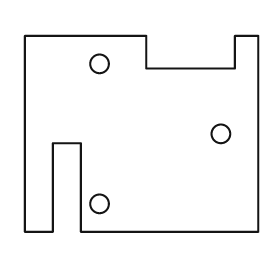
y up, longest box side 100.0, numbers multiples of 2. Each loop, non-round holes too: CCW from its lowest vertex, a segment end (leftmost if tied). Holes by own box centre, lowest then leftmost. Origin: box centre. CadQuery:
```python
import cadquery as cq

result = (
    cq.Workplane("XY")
    .moveTo(-50.0, -42.0)
    .lineTo(-38.0, -42.0)
    .lineTo(-38.0, -4.0)
    .lineTo(-26.0, -4.0)
    .lineTo(-26.0, -42.0)
    .lineTo(50.0, -42.0)
    .lineTo(50.0, 42.0)
    .lineTo(40.0, 42.0)
    .lineTo(40.0, 28.0)
    .lineTo(2.0, 28.0)
    .lineTo(2.0, 42.0)
    .lineTo(-50.0, 42.0)
    .close()
    .moveTo(-18.0, -30.0)
    .circle(4.0)
    .moveTo(34.0, 0.0)
    .circle(4.0)
    .moveTo(-18.0, 30.0)
    .circle(4.0)
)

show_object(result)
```